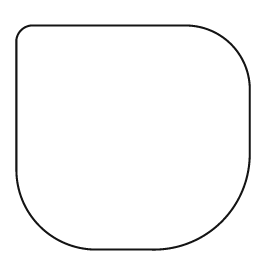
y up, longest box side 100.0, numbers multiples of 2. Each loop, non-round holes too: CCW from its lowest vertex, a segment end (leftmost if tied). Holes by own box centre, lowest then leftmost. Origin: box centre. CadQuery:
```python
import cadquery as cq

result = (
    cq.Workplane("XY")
    .moveTo(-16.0, -48.0)
    .lineTo(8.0, -48.0)
    .threePointArc((38.0, -36.0), (50.0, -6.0))
    .lineTo(50.0, 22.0)
    .threePointArc((42.0, 40.0), (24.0, 48.0))
    .lineTo(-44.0, 48.0)
    .threePointArc((-48.0, 46.0), (-50.0, 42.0))
    .lineTo(-50.0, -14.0)
    .threePointArc((-40.0, -38.0), (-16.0, -48.0))
    .close()
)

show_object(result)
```